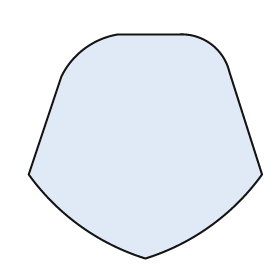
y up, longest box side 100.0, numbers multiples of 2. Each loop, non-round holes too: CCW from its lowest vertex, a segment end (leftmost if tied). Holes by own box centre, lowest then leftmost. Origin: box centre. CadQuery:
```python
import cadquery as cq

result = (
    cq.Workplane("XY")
    .moveTo(0.0, -48.0)
    .threePointArc((28.0, -34.0), (50.0, -12.0))
    .lineTo(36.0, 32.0)
    .threePointArc((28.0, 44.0), (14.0, 48.0))
    .lineTo(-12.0, 48.0)
    .threePointArc((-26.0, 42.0), (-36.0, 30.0))
    .lineTo(-50.0, -12.0)
    .threePointArc((-28.0, -34.0), (0.0, -48.0))
    .close()
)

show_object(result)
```